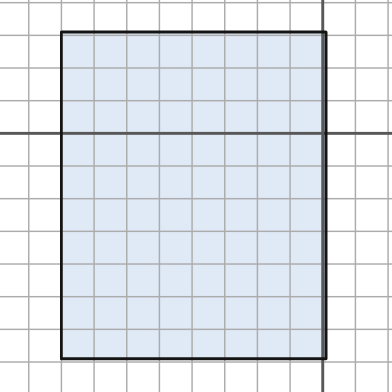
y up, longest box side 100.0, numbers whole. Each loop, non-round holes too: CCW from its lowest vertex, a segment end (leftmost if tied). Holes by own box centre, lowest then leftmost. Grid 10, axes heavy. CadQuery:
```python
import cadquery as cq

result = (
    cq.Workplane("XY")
    .moveTo(-80.0, -69.0)
    .lineTo(1.0, -69.0)
    .lineTo(1.0, 31.0)
    .lineTo(-80.0, 31.0)
    .close()
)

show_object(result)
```